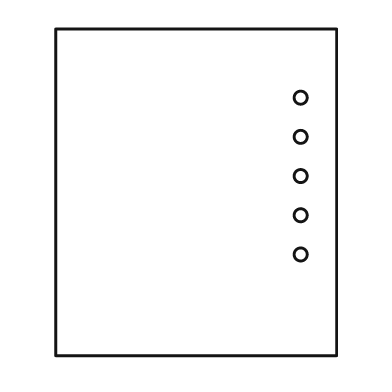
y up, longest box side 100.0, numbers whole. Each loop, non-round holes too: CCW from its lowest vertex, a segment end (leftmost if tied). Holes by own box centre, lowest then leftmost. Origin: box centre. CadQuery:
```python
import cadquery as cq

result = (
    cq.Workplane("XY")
    .moveTo(-43.0, -50.0)
    .lineTo(43.0, -50.0)
    .lineTo(43.0, 50.0)
    .lineTo(-43.0, 50.0)
    .close()
    .moveTo(32.0, -19.0)
    .circle(2.0)
    .moveTo(32.0, -7.0)
    .circle(2.0)
    .moveTo(32.0, 5.0)
    .circle(2.0)
    .moveTo(32.0, 17.0)
    .circle(2.0)
    .moveTo(32.0, 29.0)
    .circle(2.0)
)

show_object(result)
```